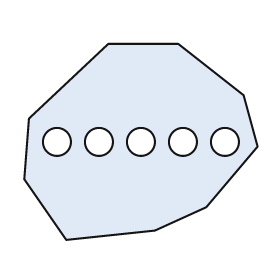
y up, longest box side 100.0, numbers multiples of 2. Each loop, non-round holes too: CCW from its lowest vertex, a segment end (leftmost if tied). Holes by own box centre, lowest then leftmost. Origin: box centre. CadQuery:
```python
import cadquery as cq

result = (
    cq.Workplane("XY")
    .moveTo(-32.0, -42.0)
    .lineTo(6.0, -38.0)
    .lineTo(28.0, -28.0)
    .lineTo(50.0, -2.0)
    .lineTo(44.0, 20.0)
    .lineTo(16.0, 42.0)
    .lineTo(-14.0, 42.0)
    .lineTo(-48.0, 10.0)
    .lineTo(-50.0, -16.0)
    .close()
    .moveTo(-36.0, 0.0)
    .circle(6.0)
    .moveTo(-18.0, 0.0)
    .circle(6.0)
    .moveTo(0.0, 0.0)
    .circle(6.0)
    .moveTo(18.0, 0.0)
    .circle(6.0)
    .moveTo(36.0, 0.0)
    .circle(6.0)
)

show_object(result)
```